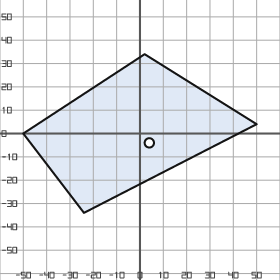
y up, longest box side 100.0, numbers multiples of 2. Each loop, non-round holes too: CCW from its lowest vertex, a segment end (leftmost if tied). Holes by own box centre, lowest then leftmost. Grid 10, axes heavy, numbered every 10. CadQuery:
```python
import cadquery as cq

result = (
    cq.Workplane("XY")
    .moveTo(-24.0, -34.0)
    .lineTo(50.0, 4.0)
    .lineTo(2.0, 34.0)
    .lineTo(-50.0, 0.0)
    .close()
    .moveTo(4.0, -4.0)
    .circle(2.0)
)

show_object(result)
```